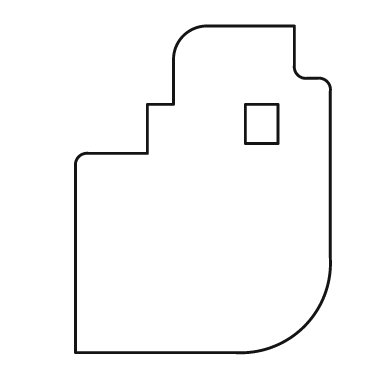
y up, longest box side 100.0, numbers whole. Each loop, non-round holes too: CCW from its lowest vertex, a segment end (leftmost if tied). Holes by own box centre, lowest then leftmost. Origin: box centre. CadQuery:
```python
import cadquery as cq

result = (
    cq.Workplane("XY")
    .moveTo(-39.0, -50.0)
    .lineTo(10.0, -50.0)
    .threePointArc((31.0, -42.0), (39.0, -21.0))
    .lineTo(39.0, 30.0)
    .threePointArc((38.0, 33.0), (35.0, 34.0))
    .lineTo(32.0, 34.0)
    .threePointArc((29.0, 35.0), (28.0, 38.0))
    .lineTo(28.0, 50.0)
    .lineTo(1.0, 50.0)
    .threePointArc((-6.0, 47.0), (-9.0, 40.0))
    .lineTo(-9.0, 26.0)
    .lineTo(-17.0, 26.0)
    .lineTo(-17.0, 11.0)
    .lineTo(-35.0, 11.0)
    .threePointArc((-38.0, 10.0), (-39.0, 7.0))
    .close()
    .moveTo(13.0, 14.0)
    .lineTo(23.0, 14.0)
    .lineTo(23.0, 26.0)
    .lineTo(13.0, 26.0)
    .close()
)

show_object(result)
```